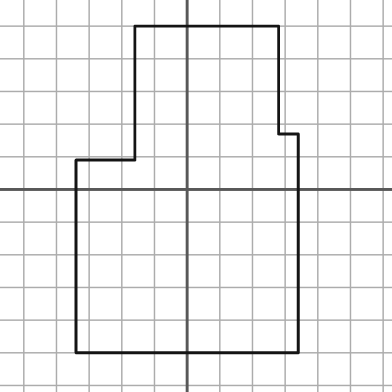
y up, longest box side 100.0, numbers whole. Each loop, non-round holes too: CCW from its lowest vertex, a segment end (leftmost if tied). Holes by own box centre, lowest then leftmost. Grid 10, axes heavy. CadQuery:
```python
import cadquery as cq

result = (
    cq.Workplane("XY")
    .moveTo(-34.0, -50.0)
    .lineTo(34.0, -50.0)
    .lineTo(34.0, 17.0)
    .lineTo(28.0, 17.0)
    .lineTo(28.0, 50.0)
    .lineTo(-16.0, 50.0)
    .lineTo(-16.0, 9.0)
    .lineTo(-34.0, 9.0)
    .close()
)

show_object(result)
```